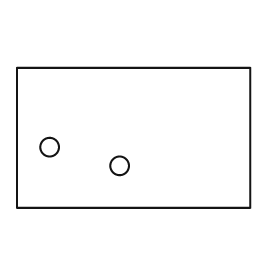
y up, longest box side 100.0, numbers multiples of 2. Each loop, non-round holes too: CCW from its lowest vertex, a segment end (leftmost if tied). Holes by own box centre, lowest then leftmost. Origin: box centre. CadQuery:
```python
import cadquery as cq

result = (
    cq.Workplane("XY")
    .moveTo(-50.0, -30.0)
    .lineTo(50.0, -30.0)
    .lineTo(50.0, 30.0)
    .lineTo(-50.0, 30.0)
    .close()
    .moveTo(-6.0, -12.0)
    .circle(4.0)
    .moveTo(-36.0, -4.0)
    .circle(4.0)
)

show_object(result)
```